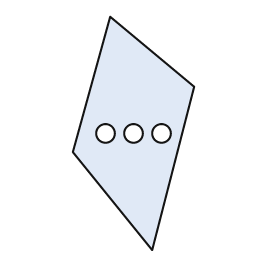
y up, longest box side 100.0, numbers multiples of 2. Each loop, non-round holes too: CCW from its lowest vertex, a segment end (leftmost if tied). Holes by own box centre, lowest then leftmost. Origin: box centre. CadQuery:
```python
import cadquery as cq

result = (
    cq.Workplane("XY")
    .moveTo(8.0, -50.0)
    .lineTo(26.0, 20.0)
    .lineTo(-10.0, 50.0)
    .lineTo(-26.0, -8.0)
    .close()
    .moveTo(-12.0, 0.0)
    .circle(4.0)
    .moveTo(0.0, 0.0)
    .circle(4.0)
    .moveTo(12.0, 0.0)
    .circle(4.0)
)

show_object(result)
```